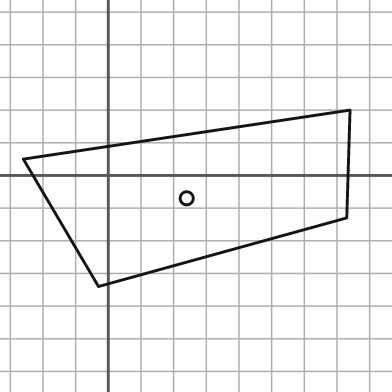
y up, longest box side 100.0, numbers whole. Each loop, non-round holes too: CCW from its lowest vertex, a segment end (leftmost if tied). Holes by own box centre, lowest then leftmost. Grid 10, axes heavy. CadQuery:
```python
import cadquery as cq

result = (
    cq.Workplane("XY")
    .moveTo(-3.0, -34.0)
    .lineTo(73.0, -13.0)
    .lineTo(74.0, 20.0)
    .lineTo(-26.0, 5.0)
    .close()
    .moveTo(24.0, -7.0)
    .circle(2.0)
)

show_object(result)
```